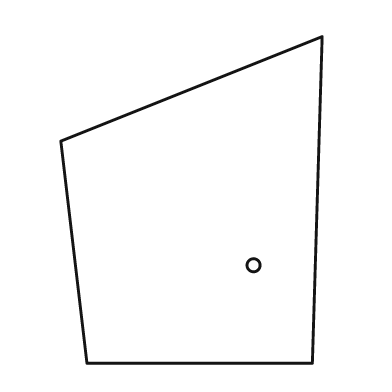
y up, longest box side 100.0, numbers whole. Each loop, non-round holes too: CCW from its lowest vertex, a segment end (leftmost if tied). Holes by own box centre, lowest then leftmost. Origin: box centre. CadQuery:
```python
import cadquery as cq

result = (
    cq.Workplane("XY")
    .moveTo(-32.0, -50.0)
    .lineTo(37.0, -50.0)
    .lineTo(40.0, 50.0)
    .lineTo(-40.0, 18.0)
    .close()
    .moveTo(19.0, -20.0)
    .circle(2.0)
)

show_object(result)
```